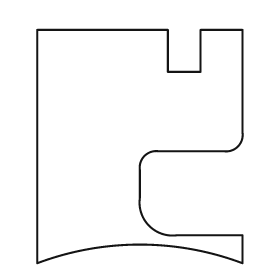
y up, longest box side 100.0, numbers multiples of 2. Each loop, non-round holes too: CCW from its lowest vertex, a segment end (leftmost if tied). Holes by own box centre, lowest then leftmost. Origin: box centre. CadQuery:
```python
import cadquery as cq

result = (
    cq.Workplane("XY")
    .moveTo(-44.0, -50.0)
    .threePointArc((0.0, -42.0), (44.0, -50.0))
    .lineTo(44.0, -38.0)
    .lineTo(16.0, -38.0)
    .threePointArc((4.0, -34.0), (0.0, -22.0))
    .lineTo(0.0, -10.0)
    .threePointArc((2.0, -4.0), (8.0, -2.0))
    .lineTo(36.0, -2.0)
    .threePointArc((42.0, 0.0), (44.0, 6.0))
    .lineTo(44.0, 50.0)
    .lineTo(26.0, 50.0)
    .lineTo(26.0, 32.0)
    .lineTo(12.0, 32.0)
    .lineTo(12.0, 50.0)
    .lineTo(-44.0, 50.0)
    .close()
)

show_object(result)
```